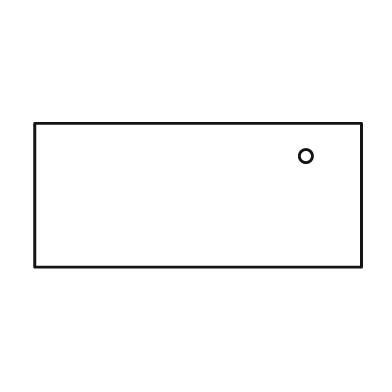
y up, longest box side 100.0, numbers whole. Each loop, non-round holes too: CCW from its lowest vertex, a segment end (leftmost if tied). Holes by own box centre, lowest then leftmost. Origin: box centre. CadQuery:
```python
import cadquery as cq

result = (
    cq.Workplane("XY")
    .moveTo(-50.0, -22.0)
    .lineTo(50.0, -22.0)
    .lineTo(50.0, 22.0)
    .lineTo(-50.0, 22.0)
    .close()
    .moveTo(33.0, 12.0)
    .circle(2.0)
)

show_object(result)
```